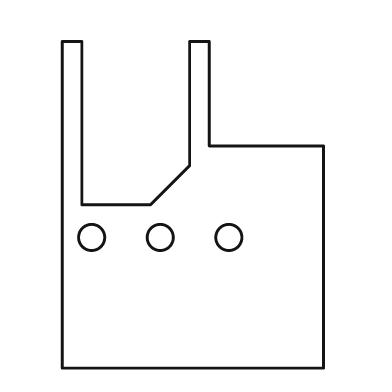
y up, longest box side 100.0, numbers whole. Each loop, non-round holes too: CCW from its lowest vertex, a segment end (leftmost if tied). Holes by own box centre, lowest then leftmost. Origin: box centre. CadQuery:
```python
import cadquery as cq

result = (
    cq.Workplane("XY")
    .moveTo(-40.0, -50.0)
    .lineTo(40.0, -50.0)
    .lineTo(40.0, 18.0)
    .lineTo(5.0, 18.0)
    .lineTo(5.0, 50.0)
    .lineTo(-1.0, 50.0)
    .lineTo(-1.0, 12.0)
    .lineTo(-13.0, 0.0)
    .lineTo(-34.0, 0.0)
    .lineTo(-34.0, 50.0)
    .lineTo(-40.0, 50.0)
    .close()
    .moveTo(-31.0, -10.0)
    .circle(4.0)
    .moveTo(-10.0, -10.0)
    .circle(4.0)
    .moveTo(11.0, -10.0)
    .circle(4.0)
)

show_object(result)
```